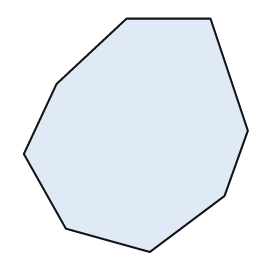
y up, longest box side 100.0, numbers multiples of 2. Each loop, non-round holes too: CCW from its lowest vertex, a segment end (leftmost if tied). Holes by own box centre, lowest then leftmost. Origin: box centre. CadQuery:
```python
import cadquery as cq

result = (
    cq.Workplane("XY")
    .moveTo(6.0, -50.0)
    .lineTo(38.0, -26.0)
    .lineTo(48.0, 2.0)
    .lineTo(32.0, 50.0)
    .lineTo(-4.0, 50.0)
    .lineTo(-34.0, 22.0)
    .lineTo(-48.0, -8.0)
    .lineTo(-30.0, -40.0)
    .close()
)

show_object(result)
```